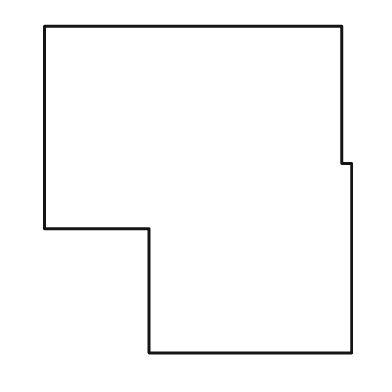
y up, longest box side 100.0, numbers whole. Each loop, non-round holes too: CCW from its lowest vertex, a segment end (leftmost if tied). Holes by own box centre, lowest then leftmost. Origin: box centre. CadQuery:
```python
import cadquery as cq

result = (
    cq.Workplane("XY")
    .moveTo(-15.0, -50.0)
    .lineTo(47.0, -50.0)
    .lineTo(47.0, 8.0)
    .lineTo(44.0, 8.0)
    .lineTo(44.0, 50.0)
    .lineTo(-47.0, 50.0)
    .lineTo(-47.0, -12.0)
    .lineTo(-15.0, -12.0)
    .close()
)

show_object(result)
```